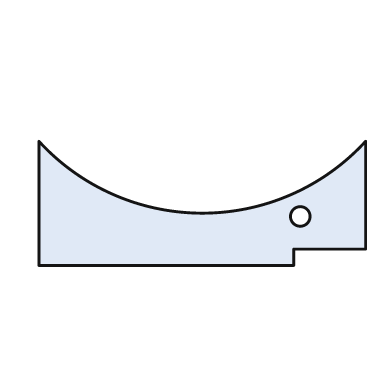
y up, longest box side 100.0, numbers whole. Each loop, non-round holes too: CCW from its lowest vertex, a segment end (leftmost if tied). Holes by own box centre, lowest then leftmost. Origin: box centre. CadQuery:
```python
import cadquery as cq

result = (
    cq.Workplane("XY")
    .moveTo(-50.0, -19.0)
    .lineTo(28.0, -19.0)
    .lineTo(28.0, -14.0)
    .lineTo(50.0, -14.0)
    .lineTo(50.0, 19.0)
    .threePointArc((0.0, -3.0), (-50.0, 19.0))
    .close()
    .moveTo(30.0, -4.0)
    .circle(3.0)
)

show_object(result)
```